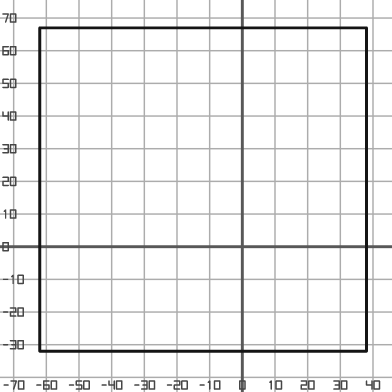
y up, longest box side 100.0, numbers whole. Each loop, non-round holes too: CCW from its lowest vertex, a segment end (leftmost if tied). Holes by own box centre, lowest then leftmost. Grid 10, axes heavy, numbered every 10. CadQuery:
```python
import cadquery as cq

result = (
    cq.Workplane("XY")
    .moveTo(-62.0, -32.0)
    .lineTo(38.0, -32.0)
    .lineTo(38.0, 67.0)
    .lineTo(-62.0, 67.0)
    .close()
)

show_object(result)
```